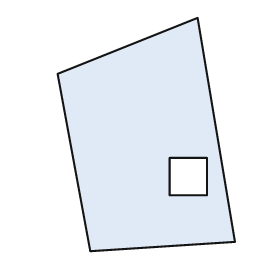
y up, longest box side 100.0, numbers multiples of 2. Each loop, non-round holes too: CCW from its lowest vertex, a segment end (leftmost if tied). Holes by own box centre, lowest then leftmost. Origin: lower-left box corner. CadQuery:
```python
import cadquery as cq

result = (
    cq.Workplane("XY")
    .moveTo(14.0, 0.0)
    .lineTo(76.0, 4.0)
    .lineTo(60.0, 100.0)
    .lineTo(0.0, 76.0)
    .close()
    .moveTo(48.0, 24.0)
    .lineTo(64.0, 24.0)
    .lineTo(64.0, 40.0)
    .lineTo(48.0, 40.0)
    .close()
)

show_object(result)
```